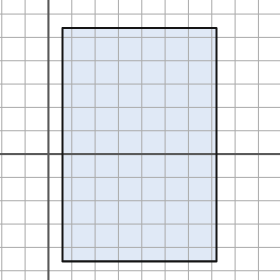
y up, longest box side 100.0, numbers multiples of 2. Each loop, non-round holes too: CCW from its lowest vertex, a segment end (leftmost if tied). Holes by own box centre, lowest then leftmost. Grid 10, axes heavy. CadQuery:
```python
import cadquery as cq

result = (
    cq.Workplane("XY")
    .moveTo(6.0, -46.0)
    .lineTo(72.0, -46.0)
    .lineTo(72.0, 54.0)
    .lineTo(6.0, 54.0)
    .close()
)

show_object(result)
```